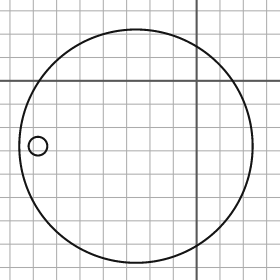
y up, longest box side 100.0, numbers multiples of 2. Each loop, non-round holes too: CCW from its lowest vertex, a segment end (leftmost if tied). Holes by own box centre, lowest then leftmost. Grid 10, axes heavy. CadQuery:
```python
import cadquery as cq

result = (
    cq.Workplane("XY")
    .moveTo(-26.0, -28.0)
    .circle(50.0)
    .moveTo(-68.0, -28.0)
    .circle(4.0)
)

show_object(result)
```